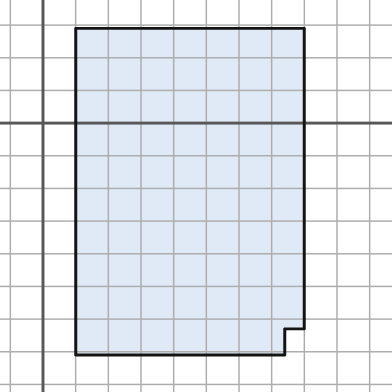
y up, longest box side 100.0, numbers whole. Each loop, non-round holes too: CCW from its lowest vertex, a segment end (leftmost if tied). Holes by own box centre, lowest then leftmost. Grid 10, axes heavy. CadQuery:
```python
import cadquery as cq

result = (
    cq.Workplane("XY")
    .moveTo(10.0, -71.0)
    .lineTo(74.0, -71.0)
    .lineTo(74.0, -63.0)
    .lineTo(80.0, -63.0)
    .lineTo(80.0, 29.0)
    .lineTo(10.0, 29.0)
    .close()
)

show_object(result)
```